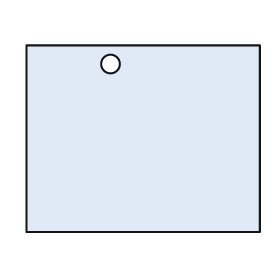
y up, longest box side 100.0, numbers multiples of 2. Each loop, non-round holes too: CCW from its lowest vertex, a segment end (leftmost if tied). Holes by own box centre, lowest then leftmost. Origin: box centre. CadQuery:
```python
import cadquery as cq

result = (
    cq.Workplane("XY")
    .moveTo(-50.0, -40.0)
    .lineTo(50.0, -40.0)
    .lineTo(50.0, 40.0)
    .lineTo(-50.0, 40.0)
    .close()
    .moveTo(-14.0, 32.0)
    .circle(4.0)
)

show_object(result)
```